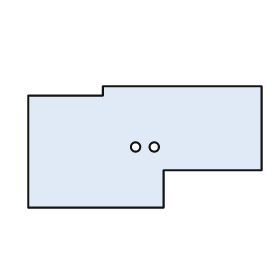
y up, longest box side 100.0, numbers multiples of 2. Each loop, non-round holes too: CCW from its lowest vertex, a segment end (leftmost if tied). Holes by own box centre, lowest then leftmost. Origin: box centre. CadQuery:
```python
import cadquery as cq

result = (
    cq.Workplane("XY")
    .moveTo(-50.0, -26.0)
    .lineTo(8.0, -26.0)
    .lineTo(8.0, -10.0)
    .lineTo(50.0, -10.0)
    .lineTo(50.0, 26.0)
    .lineTo(-18.0, 26.0)
    .lineTo(-18.0, 22.0)
    .lineTo(-50.0, 22.0)
    .close()
    .moveTo(-4.0, 0.0)
    .circle(2.0)
    .moveTo(4.0, 0.0)
    .circle(2.0)
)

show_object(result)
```